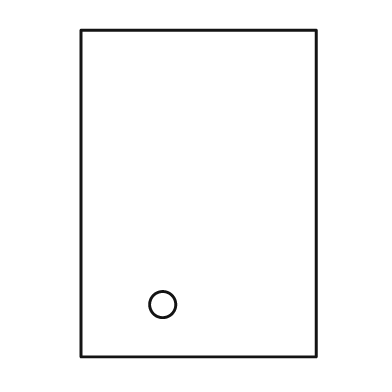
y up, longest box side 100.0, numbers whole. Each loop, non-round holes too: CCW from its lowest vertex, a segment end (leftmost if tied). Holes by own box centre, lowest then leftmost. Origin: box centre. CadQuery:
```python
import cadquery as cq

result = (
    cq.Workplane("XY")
    .moveTo(-36.0, -50.0)
    .lineTo(36.0, -50.0)
    .lineTo(36.0, 50.0)
    .lineTo(-36.0, 50.0)
    .close()
    .moveTo(-11.0, -34.0)
    .circle(4.0)
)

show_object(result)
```